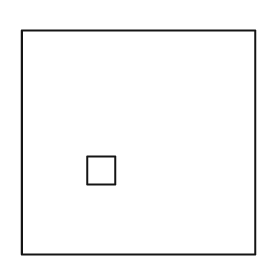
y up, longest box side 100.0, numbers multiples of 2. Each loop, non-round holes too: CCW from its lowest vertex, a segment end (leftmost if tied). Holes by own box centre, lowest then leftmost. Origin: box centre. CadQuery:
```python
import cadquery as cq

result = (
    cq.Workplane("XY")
    .moveTo(-50.0, -48.0)
    .lineTo(50.0, -48.0)
    .lineTo(50.0, 48.0)
    .lineTo(-50.0, 48.0)
    .close()
    .moveTo(-22.0, -18.0)
    .lineTo(-10.0, -18.0)
    .lineTo(-10.0, -6.0)
    .lineTo(-22.0, -6.0)
    .close()
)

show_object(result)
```